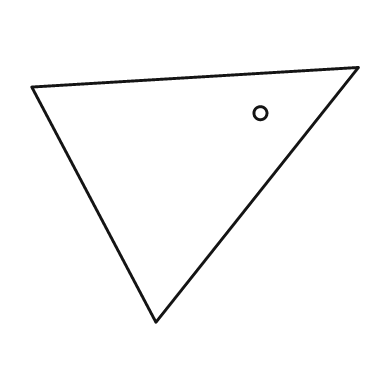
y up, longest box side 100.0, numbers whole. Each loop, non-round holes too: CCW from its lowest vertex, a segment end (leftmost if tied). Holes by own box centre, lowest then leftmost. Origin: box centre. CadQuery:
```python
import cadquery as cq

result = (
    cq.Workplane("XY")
    .moveTo(-12.0, -39.0)
    .lineTo(50.0, 39.0)
    .lineTo(-50.0, 33.0)
    .close()
    .moveTo(20.0, 25.0)
    .circle(2.0)
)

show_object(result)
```